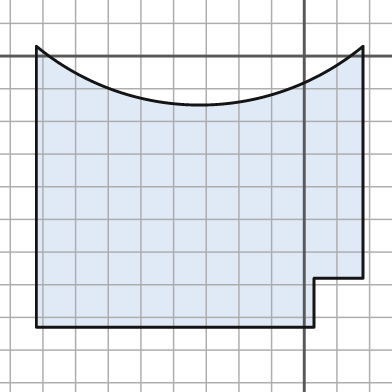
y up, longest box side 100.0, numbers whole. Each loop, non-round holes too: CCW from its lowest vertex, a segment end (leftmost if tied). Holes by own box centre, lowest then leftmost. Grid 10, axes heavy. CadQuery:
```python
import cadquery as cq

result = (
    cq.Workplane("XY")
    .moveTo(-82.0, -83.0)
    .lineTo(3.0, -83.0)
    .lineTo(3.0, -68.0)
    .lineTo(18.0, -68.0)
    .lineTo(18.0, 3.0)
    .threePointArc((-32.0, -15.0), (-82.0, 3.0))
    .close()
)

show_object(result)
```